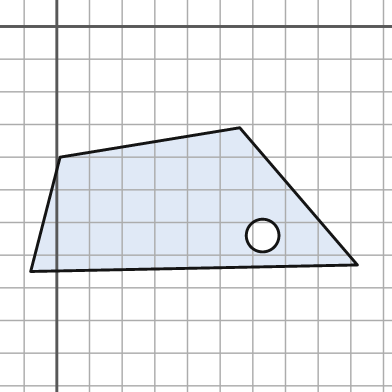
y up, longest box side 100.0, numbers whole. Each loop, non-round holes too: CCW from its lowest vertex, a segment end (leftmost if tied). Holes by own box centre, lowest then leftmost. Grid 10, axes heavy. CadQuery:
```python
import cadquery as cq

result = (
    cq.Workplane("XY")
    .moveTo(-8.0, -75.0)
    .lineTo(92.0, -73.0)
    .lineTo(56.0, -31.0)
    .lineTo(1.0, -40.0)
    .close()
    .moveTo(63.0, -64.0)
    .circle(5.0)
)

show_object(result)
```